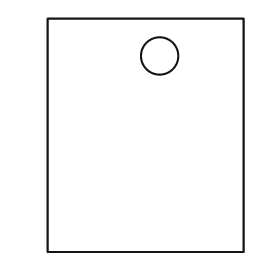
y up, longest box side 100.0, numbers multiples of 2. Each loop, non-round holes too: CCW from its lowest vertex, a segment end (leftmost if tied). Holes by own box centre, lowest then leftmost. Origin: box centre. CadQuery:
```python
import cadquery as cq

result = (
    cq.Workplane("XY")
    .moveTo(-42.0, -50.0)
    .lineTo(42.0, -50.0)
    .lineTo(42.0, 50.0)
    .lineTo(-42.0, 50.0)
    .close()
    .moveTo(6.0, 34.0)
    .circle(8.0)
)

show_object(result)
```